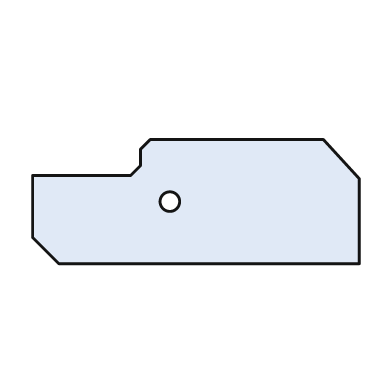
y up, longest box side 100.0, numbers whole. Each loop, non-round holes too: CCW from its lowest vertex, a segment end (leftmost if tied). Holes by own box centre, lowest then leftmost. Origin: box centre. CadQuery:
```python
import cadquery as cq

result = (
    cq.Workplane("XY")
    .moveTo(-42.0, -19.0)
    .lineTo(50.0, -19.0)
    .lineTo(50.0, 7.0)
    .lineTo(39.0, 19.0)
    .lineTo(-14.0, 19.0)
    .lineTo(-17.0, 16.0)
    .lineTo(-17.0, 11.0)
    .lineTo(-20.0, 8.0)
    .lineTo(-50.0, 8.0)
    .lineTo(-50.0, -11.0)
    .close()
    .moveTo(-8.0, 0.0)
    .circle(3.0)
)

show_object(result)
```